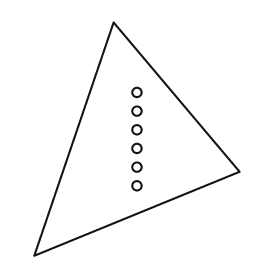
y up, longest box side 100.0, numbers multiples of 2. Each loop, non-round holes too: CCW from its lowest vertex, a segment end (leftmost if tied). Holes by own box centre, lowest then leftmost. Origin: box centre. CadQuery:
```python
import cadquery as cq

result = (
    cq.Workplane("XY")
    .moveTo(-44.0, -50.0)
    .lineTo(44.0, -14.0)
    .lineTo(-10.0, 50.0)
    .close()
    .moveTo(0.0, -20.0)
    .circle(2.0)
    .moveTo(0.0, -12.0)
    .circle(2.0)
    .moveTo(0.0, -4.0)
    .circle(2.0)
    .moveTo(0.0, 4.0)
    .circle(2.0)
    .moveTo(0.0, 12.0)
    .circle(2.0)
    .moveTo(0.0, 20.0)
    .circle(2.0)
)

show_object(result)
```